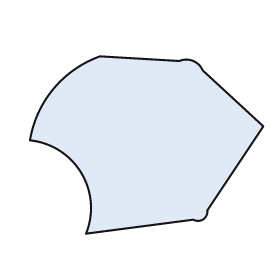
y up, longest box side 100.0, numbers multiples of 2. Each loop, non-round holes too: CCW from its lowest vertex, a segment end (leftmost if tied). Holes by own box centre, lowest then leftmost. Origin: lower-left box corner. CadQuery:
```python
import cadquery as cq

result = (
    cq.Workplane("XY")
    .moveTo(24.0, 0.0)
    .lineTo(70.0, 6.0)
    .threePointArc((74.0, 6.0), (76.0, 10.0))
    .lineTo(100.0, 46.0)
    .lineTo(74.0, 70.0)
    .threePointArc((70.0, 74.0), (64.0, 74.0))
    .lineTo(30.0, 76.0)
    .threePointArc((10.0, 62.0), (0.0, 40.0))
    .threePointArc((22.0, 26.0), (24.0, 0.0))
    .close()
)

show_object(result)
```